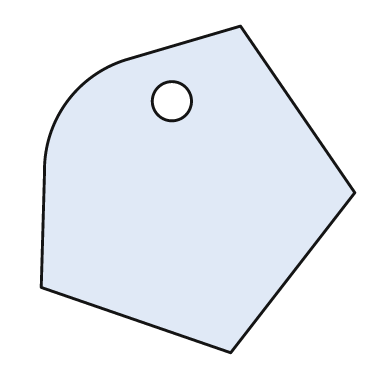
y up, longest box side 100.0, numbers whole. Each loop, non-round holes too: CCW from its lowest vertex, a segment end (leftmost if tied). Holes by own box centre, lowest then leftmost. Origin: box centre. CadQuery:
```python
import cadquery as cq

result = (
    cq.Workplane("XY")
    .moveTo(10.0, -50.0)
    .lineTo(48.0, -1.0)
    .lineTo(13.0, 50.0)
    .lineTo(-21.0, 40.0)
    .threePointArc((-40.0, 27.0), (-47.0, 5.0))
    .lineTo(-48.0, -30.0)
    .close()
    .moveTo(-8.0, 27.0)
    .circle(6.0)
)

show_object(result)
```